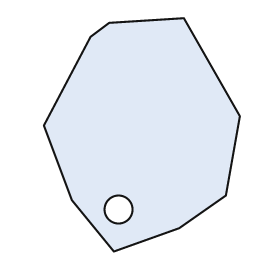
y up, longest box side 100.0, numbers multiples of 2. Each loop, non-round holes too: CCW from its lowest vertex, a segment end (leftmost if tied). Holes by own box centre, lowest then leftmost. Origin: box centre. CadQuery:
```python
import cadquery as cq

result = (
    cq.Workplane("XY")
    .moveTo(-12.0, -50.0)
    .lineTo(16.0, -40.0)
    .lineTo(36.0, -26.0)
    .lineTo(42.0, 8.0)
    .lineTo(18.0, 50.0)
    .lineTo(-14.0, 48.0)
    .lineTo(-22.0, 42.0)
    .lineTo(-42.0, 4.0)
    .lineTo(-30.0, -28.0)
    .close()
    .moveTo(-10.0, -32.0)
    .circle(6.0)
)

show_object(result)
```